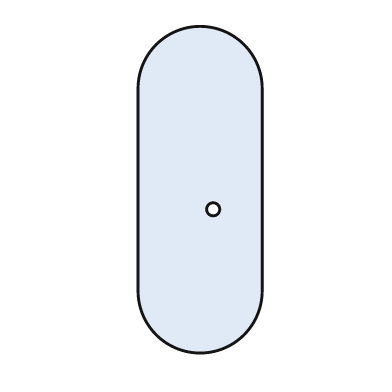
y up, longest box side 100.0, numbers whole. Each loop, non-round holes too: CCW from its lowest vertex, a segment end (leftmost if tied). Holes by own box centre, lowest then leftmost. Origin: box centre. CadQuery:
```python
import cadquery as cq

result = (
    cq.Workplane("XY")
    .moveTo(-19.0, -31.0)
    .threePointArc((0.0, -50.0), (19.0, -31.0))
    .lineTo(19.0, 31.0)
    .threePointArc((0.0, 50.0), (-19.0, 31.0))
    .close()
    .moveTo(4.0, -6.0)
    .circle(2.0)
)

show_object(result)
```